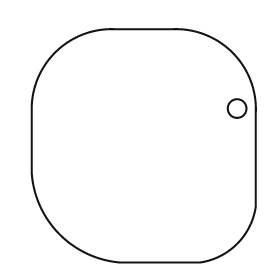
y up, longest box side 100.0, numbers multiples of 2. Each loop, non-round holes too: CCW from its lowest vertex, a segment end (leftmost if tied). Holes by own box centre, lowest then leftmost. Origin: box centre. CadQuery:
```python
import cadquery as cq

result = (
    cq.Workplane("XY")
    .moveTo(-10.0, -50.0)
    .lineTo(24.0, -50.0)
    .threePointArc((40.0, -42.0), (48.0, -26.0))
    .lineTo(48.0, 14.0)
    .threePointArc((38.0, 40.0), (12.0, 50.0))
    .lineTo(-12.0, 50.0)
    .threePointArc((-38.0, 40.0), (-48.0, 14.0))
    .lineTo(-48.0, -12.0)
    .threePointArc((-36.0, -38.0), (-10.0, -50.0))
    .close()
    .moveTo(40.0, 16.0)
    .circle(4.0)
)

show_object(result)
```